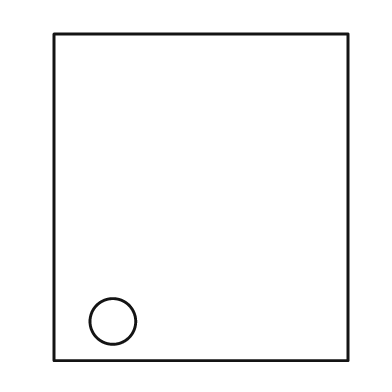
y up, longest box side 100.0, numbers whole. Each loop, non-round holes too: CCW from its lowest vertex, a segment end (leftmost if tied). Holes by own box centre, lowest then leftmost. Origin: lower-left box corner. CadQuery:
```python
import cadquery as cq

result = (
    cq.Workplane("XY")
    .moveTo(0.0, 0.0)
    .lineTo(90.0, 0.0)
    .lineTo(90.0, 100.0)
    .lineTo(0.0, 100.0)
    .close()
    .moveTo(18.0, 12.0)
    .circle(7.0)
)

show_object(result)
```